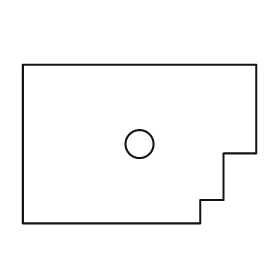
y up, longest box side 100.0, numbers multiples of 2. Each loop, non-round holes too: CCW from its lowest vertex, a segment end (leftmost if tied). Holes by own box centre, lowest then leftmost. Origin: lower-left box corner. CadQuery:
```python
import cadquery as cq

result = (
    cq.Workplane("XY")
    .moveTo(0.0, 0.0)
    .lineTo(76.0, 0.0)
    .lineTo(76.0, 10.0)
    .lineTo(86.0, 10.0)
    .lineTo(86.0, 30.0)
    .lineTo(100.0, 30.0)
    .lineTo(100.0, 68.0)
    .lineTo(0.0, 68.0)
    .close()
    .moveTo(50.0, 34.0)
    .circle(6.0)
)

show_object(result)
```